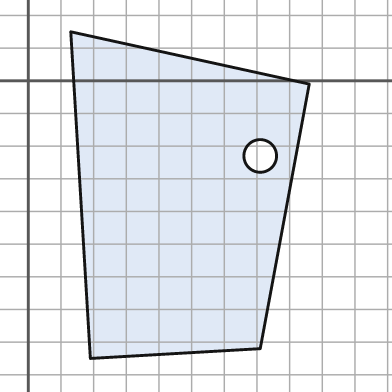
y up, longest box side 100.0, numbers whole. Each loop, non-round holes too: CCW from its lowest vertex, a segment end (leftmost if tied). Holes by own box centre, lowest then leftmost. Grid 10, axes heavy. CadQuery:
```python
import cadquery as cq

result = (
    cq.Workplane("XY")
    .moveTo(19.0, -85.0)
    .lineTo(71.0, -82.0)
    .lineTo(86.0, -1.0)
    .lineTo(13.0, 15.0)
    .close()
    .moveTo(71.0, -23.0)
    .circle(5.0)
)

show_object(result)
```